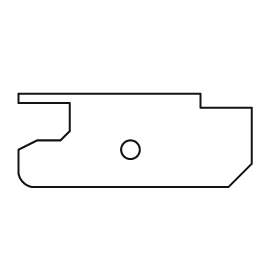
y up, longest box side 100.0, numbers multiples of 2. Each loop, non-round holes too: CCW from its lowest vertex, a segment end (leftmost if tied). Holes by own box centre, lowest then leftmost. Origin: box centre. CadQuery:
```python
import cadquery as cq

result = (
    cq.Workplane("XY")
    .moveTo(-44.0, -20.0)
    .lineTo(40.0, -20.0)
    .lineTo(50.0, -10.0)
    .lineTo(50.0, 14.0)
    .lineTo(28.0, 14.0)
    .lineTo(28.0, 20.0)
    .lineTo(-50.0, 20.0)
    .lineTo(-50.0, 16.0)
    .lineTo(-28.0, 16.0)
    .lineTo(-28.0, 4.0)
    .lineTo(-32.0, 0.0)
    .lineTo(-42.0, 0.0)
    .lineTo(-50.0, -4.0)
    .lineTo(-50.0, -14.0)
    .threePointArc((-48.0, -18.0), (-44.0, -20.0))
    .close()
    .moveTo(-2.0, -4.0)
    .circle(4.0)
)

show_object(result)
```